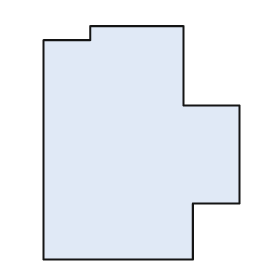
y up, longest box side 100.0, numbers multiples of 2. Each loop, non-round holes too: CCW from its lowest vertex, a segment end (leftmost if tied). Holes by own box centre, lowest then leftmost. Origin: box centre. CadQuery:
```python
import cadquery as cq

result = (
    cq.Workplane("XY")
    .moveTo(-42.0, -50.0)
    .lineTo(22.0, -50.0)
    .lineTo(22.0, -26.0)
    .lineTo(42.0, -26.0)
    .lineTo(42.0, 16.0)
    .lineTo(18.0, 16.0)
    .lineTo(18.0, 50.0)
    .lineTo(-22.0, 50.0)
    .lineTo(-22.0, 44.0)
    .lineTo(-42.0, 44.0)
    .close()
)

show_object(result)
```